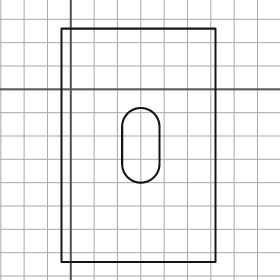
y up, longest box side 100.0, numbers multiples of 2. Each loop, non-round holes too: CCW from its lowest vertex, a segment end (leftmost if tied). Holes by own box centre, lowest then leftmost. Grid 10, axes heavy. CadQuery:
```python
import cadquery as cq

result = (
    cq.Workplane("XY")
    .moveTo(-4.0, -74.0)
    .lineTo(62.0, -74.0)
    .lineTo(62.0, 26.0)
    .lineTo(-4.0, 26.0)
    .close()
    .moveTo(22.0, -32.0)
    .threePointArc((30.0, -40.0), (38.0, -32.0))
    .lineTo(38.0, -16.0)
    .threePointArc((30.0, -8.0), (22.0, -16.0))
    .close()
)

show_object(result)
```